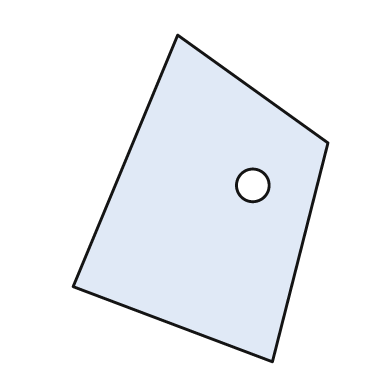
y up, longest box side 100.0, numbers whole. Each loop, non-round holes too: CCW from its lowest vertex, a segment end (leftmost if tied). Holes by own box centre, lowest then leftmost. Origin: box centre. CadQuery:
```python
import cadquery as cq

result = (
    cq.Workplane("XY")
    .moveTo(22.0, -50.0)
    .lineTo(39.0, 17.0)
    .lineTo(-7.0, 50.0)
    .lineTo(-39.0, -27.0)
    .close()
    .moveTo(16.0, 4.0)
    .circle(5.0)
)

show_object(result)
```